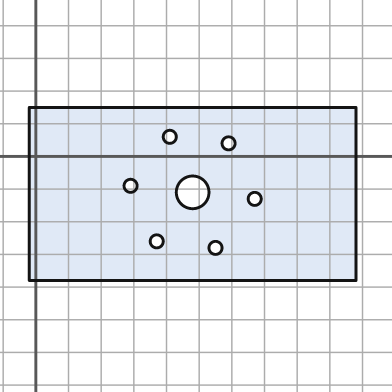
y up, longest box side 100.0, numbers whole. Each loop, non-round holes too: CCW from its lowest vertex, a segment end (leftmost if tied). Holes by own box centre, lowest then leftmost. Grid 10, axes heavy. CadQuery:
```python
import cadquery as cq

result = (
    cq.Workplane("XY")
    .moveTo(-2.0, -38.0)
    .lineTo(98.0, -38.0)
    .lineTo(98.0, 15.0)
    .lineTo(-2.0, 15.0)
    .close()
    .moveTo(55.0, -28.0)
    .circle(2.0)
    .moveTo(37.0, -26.0)
    .circle(2.0)
    .moveTo(67.0, -13.0)
    .circle(2.0)
    .moveTo(48.0, -11.0)
    .circle(5.0)
    .moveTo(29.0, -9.0)
    .circle(2.0)
    .moveTo(59.0, 4.0)
    .circle(2.0)
    .moveTo(41.0, 6.0)
    .circle(2.0)
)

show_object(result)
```